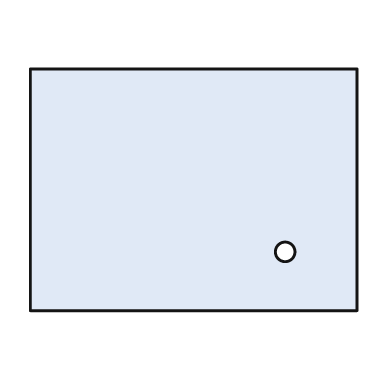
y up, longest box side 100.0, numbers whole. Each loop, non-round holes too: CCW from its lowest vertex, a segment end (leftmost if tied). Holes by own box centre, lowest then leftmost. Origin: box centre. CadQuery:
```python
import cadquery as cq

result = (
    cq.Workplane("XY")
    .moveTo(-50.0, -37.0)
    .lineTo(50.0, -37.0)
    .lineTo(50.0, 37.0)
    .lineTo(-50.0, 37.0)
    .close()
    .moveTo(28.0, -19.0)
    .circle(3.0)
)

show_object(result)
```